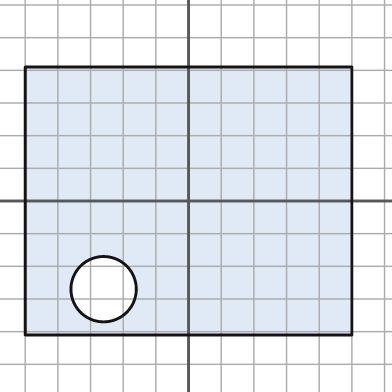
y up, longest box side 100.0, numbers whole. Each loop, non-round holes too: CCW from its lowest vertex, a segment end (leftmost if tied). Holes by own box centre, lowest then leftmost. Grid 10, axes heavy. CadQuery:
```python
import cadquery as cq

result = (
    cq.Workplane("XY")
    .moveTo(-50.0, -41.0)
    .lineTo(50.0, -41.0)
    .lineTo(50.0, 41.0)
    .lineTo(-50.0, 41.0)
    .close()
    .moveTo(-26.0, -27.0)
    .circle(10.0)
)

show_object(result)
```